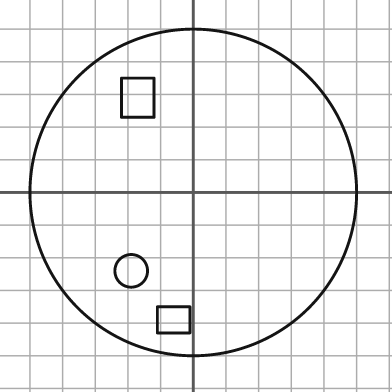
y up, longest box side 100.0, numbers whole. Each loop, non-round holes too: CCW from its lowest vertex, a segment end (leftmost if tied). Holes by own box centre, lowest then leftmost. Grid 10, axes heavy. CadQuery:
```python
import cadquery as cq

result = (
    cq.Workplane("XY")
    .moveTo(0.0, 0.0)
    .circle(50.0)
    .moveTo(-11.0, -43.0)
    .lineTo(-1.0, -43.0)
    .lineTo(-1.0, -35.0)
    .lineTo(-11.0, -35.0)
    .close()
    .moveTo(-19.0, -24.0)
    .circle(5.0)
    .moveTo(-22.0, 23.0)
    .lineTo(-12.0, 23.0)
    .lineTo(-12.0, 35.0)
    .lineTo(-22.0, 35.0)
    .close()
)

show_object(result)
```